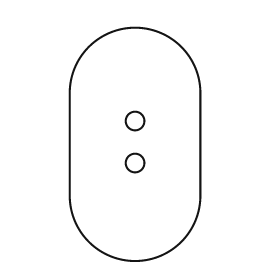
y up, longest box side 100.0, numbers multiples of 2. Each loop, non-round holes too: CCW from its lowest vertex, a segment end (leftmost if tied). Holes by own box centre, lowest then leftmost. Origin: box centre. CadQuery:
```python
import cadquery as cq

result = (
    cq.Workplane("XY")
    .moveTo(-28.0, -22.0)
    .threePointArc((0.0, -50.0), (28.0, -22.0))
    .lineTo(28.0, 22.0)
    .threePointArc((0.0, 50.0), (-28.0, 22.0))
    .close()
    .moveTo(0.0, -8.0)
    .circle(4.0)
    .moveTo(0.0, 10.0)
    .circle(4.0)
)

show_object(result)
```